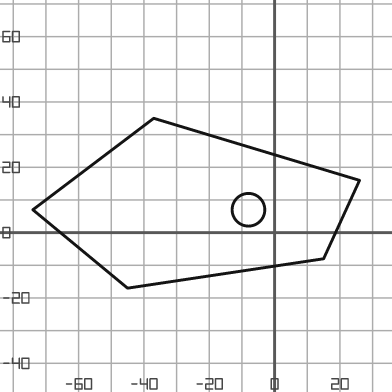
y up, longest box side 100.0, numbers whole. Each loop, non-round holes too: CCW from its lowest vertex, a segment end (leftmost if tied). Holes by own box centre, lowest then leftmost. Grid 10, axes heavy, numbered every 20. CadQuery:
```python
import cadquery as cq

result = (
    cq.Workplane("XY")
    .moveTo(-45.0, -17.0)
    .lineTo(15.0, -8.0)
    .lineTo(26.0, 16.0)
    .lineTo(-37.0, 35.0)
    .lineTo(-74.0, 7.0)
    .close()
    .moveTo(-8.0, 7.0)
    .circle(5.0)
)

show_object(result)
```